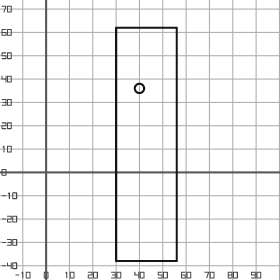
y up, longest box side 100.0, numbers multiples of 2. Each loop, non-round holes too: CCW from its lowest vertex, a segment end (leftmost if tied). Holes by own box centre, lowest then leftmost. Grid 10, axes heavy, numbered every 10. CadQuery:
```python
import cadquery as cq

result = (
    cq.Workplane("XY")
    .moveTo(30.0, -38.0)
    .lineTo(56.0, -38.0)
    .lineTo(56.0, 62.0)
    .lineTo(30.0, 62.0)
    .close()
    .moveTo(40.0, 36.0)
    .circle(2.0)
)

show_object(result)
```